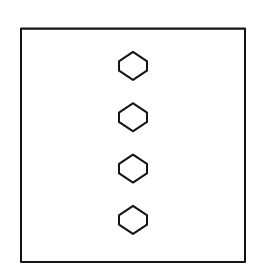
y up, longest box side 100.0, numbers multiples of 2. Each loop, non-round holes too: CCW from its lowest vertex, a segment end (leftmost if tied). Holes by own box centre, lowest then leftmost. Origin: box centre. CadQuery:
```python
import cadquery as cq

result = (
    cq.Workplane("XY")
    .moveTo(-48.0, -50.0)
    .lineTo(48.0, -50.0)
    .lineTo(48.0, 50.0)
    .lineTo(-48.0, 50.0)
    .close()
    .moveTo(0.0, -38.0)
    .lineTo(6.0, -34.0)
    .lineTo(6.0, -30.0)
    .lineTo(0.0, -26.0)
    .lineTo(-6.0, -30.0)
    .lineTo(-6.0, -34.0)
    .close()
    .moveTo(0.0, -16.0)
    .lineTo(6.0, -12.0)
    .lineTo(6.0, -8.0)
    .lineTo(0.0, -4.0)
    .lineTo(-6.0, -8.0)
    .lineTo(-6.0, -12.0)
    .close()
    .moveTo(0.0, 6.0)
    .lineTo(6.0, 10.0)
    .lineTo(6.0, 14.0)
    .lineTo(0.0, 18.0)
    .lineTo(-6.0, 14.0)
    .lineTo(-6.0, 10.0)
    .close()
    .moveTo(0.0, 28.0)
    .lineTo(6.0, 32.0)
    .lineTo(6.0, 36.0)
    .lineTo(0.0, 40.0)
    .lineTo(-6.0, 36.0)
    .lineTo(-6.0, 32.0)
    .close()
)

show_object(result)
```